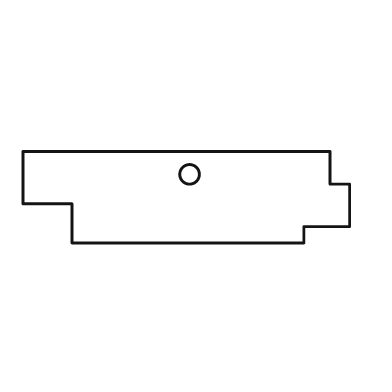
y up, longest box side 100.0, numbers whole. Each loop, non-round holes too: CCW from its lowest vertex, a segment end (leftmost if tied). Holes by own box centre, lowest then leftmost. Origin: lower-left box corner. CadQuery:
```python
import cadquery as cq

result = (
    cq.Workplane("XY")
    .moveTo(15.0, 0.0)
    .lineTo(86.0, 0.0)
    .lineTo(86.0, 5.0)
    .lineTo(100.0, 5.0)
    .lineTo(100.0, 18.0)
    .lineTo(94.0, 18.0)
    .lineTo(94.0, 28.0)
    .lineTo(0.0, 28.0)
    .lineTo(0.0, 12.0)
    .lineTo(15.0, 12.0)
    .close()
    .moveTo(51.0, 21.0)
    .circle(3.0)
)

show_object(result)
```